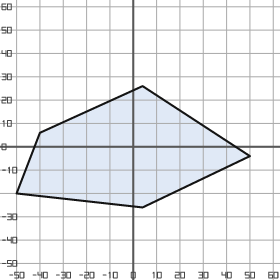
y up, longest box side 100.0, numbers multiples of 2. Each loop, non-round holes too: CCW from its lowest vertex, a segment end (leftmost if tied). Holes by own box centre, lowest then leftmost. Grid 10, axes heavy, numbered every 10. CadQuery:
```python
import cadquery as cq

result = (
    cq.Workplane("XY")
    .moveTo(4.0, -26.0)
    .lineTo(50.0, -4.0)
    .lineTo(4.0, 26.0)
    .lineTo(-40.0, 6.0)
    .lineTo(-50.0, -20.0)
    .close()
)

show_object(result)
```